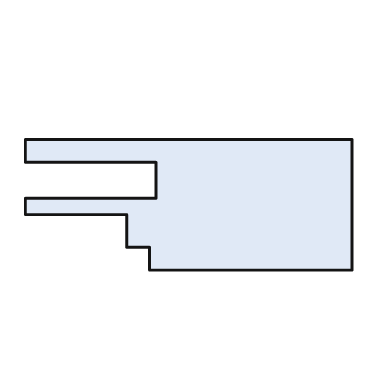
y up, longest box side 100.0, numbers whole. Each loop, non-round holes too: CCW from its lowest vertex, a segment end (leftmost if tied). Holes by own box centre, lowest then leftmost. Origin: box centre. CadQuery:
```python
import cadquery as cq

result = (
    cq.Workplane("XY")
    .moveTo(-12.0, -20.0)
    .lineTo(50.0, -20.0)
    .lineTo(50.0, 20.0)
    .lineTo(-50.0, 20.0)
    .lineTo(-50.0, 13.0)
    .lineTo(-10.0, 13.0)
    .lineTo(-10.0, 2.0)
    .lineTo(-50.0, 2.0)
    .lineTo(-50.0, -3.0)
    .lineTo(-19.0, -3.0)
    .lineTo(-19.0, -13.0)
    .lineTo(-12.0, -13.0)
    .close()
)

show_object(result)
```